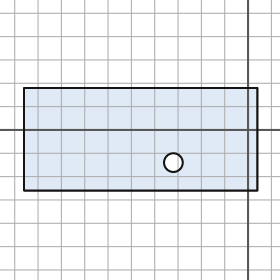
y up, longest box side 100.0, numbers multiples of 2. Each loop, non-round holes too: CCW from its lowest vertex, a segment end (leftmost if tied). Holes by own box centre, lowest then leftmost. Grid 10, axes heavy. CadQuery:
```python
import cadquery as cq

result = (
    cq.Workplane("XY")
    .moveTo(-96.0, -26.0)
    .lineTo(4.0, -26.0)
    .lineTo(4.0, 18.0)
    .lineTo(-96.0, 18.0)
    .close()
    .moveTo(-32.0, -14.0)
    .circle(4.0)
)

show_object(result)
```